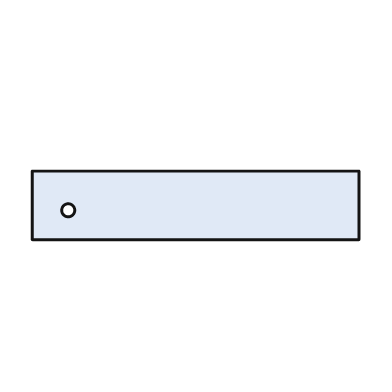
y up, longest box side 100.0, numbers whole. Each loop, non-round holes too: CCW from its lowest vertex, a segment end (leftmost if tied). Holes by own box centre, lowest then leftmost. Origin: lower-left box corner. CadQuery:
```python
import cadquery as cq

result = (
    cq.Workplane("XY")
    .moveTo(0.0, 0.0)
    .lineTo(100.0, 0.0)
    .lineTo(100.0, 21.0)
    .lineTo(0.0, 21.0)
    .close()
    .moveTo(11.0, 9.0)
    .circle(2.0)
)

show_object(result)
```